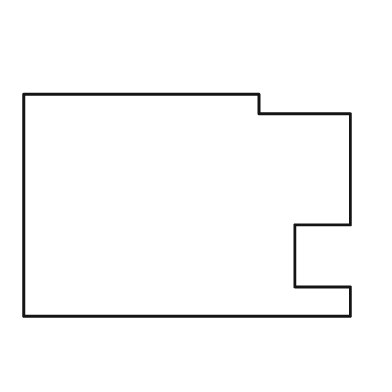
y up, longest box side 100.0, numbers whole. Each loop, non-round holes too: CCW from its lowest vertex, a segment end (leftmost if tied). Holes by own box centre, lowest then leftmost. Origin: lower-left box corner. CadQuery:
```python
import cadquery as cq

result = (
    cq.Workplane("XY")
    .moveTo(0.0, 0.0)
    .lineTo(100.0, 0.0)
    .lineTo(100.0, 9.0)
    .lineTo(83.0, 9.0)
    .lineTo(83.0, 28.0)
    .lineTo(100.0, 28.0)
    .lineTo(100.0, 62.0)
    .lineTo(72.0, 62.0)
    .lineTo(72.0, 68.0)
    .lineTo(0.0, 68.0)
    .close()
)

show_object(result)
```